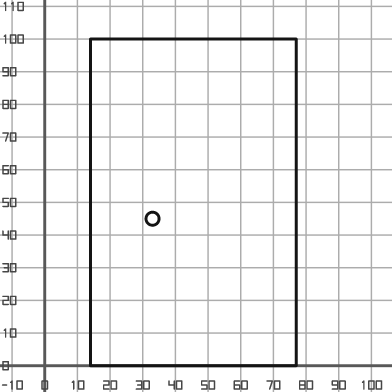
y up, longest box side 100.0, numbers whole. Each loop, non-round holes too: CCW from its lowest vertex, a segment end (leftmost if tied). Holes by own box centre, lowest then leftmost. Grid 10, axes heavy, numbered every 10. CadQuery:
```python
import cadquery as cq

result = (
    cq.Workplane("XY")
    .moveTo(14.0, 0.0)
    .lineTo(77.0, 0.0)
    .lineTo(77.0, 100.0)
    .lineTo(14.0, 100.0)
    .close()
    .moveTo(33.0, 45.0)
    .circle(2.0)
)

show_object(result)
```